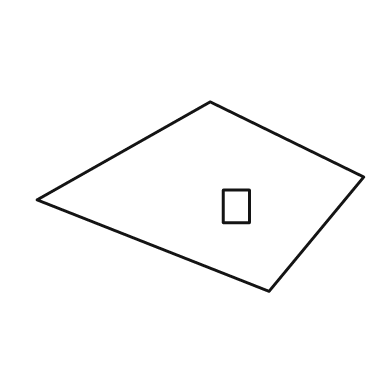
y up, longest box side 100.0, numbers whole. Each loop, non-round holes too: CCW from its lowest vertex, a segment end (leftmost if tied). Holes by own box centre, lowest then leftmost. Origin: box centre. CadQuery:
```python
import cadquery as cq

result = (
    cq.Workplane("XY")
    .moveTo(21.0, -29.0)
    .lineTo(50.0, 6.0)
    .lineTo(3.0, 29.0)
    .lineTo(-50.0, -1.0)
    .close()
    .moveTo(7.0, -8.0)
    .lineTo(15.0, -8.0)
    .lineTo(15.0, 2.0)
    .lineTo(7.0, 2.0)
    .close()
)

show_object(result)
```